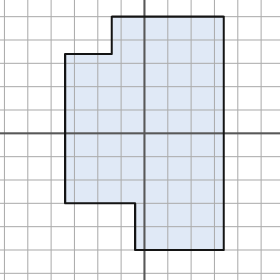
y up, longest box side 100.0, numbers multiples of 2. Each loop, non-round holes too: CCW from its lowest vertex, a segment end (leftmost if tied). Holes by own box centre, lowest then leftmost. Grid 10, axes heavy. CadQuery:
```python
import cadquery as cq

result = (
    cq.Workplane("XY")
    .moveTo(-4.0, -50.0)
    .lineTo(34.0, -50.0)
    .lineTo(34.0, 50.0)
    .lineTo(-14.0, 50.0)
    .lineTo(-14.0, 34.0)
    .lineTo(-34.0, 34.0)
    .lineTo(-34.0, -30.0)
    .lineTo(-4.0, -30.0)
    .close()
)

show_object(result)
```